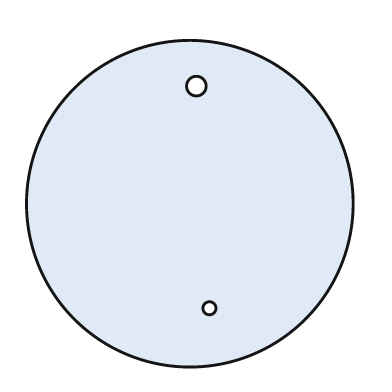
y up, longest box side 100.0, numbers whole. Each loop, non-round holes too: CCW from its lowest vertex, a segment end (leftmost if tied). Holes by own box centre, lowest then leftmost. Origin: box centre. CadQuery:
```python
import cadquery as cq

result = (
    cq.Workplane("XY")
    .moveTo(0.0, 0.0)
    .circle(50.0)
    .moveTo(6.0, -32.0)
    .circle(2.0)
    .moveTo(2.0, 36.0)
    .circle(3.0)
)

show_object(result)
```